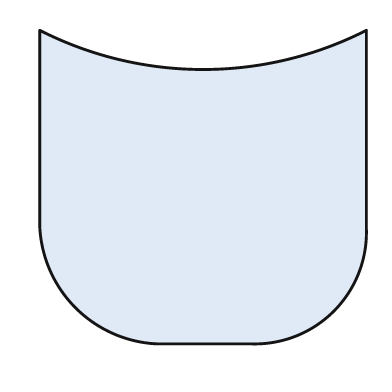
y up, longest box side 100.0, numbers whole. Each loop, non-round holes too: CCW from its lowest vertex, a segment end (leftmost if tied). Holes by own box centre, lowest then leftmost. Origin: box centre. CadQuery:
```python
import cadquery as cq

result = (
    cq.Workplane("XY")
    .moveTo(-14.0, -48.0)
    .lineTo(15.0, -48.0)
    .threePointArc((40.0, -38.0), (50.0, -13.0))
    .lineTo(50.0, 48.0)
    .threePointArc((0.0, 36.0), (-50.0, 48.0))
    .lineTo(-50.0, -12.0)
    .threePointArc((-39.0, -37.0), (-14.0, -48.0))
    .close()
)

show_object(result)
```